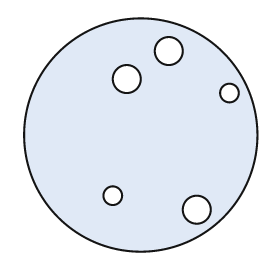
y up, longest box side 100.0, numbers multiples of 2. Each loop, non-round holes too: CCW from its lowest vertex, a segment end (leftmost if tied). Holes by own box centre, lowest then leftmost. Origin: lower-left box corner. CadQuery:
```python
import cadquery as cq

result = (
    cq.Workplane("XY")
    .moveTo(50.0, 50.0)
    .circle(50.0)
    .moveTo(74.0, 18.0)
    .circle(6.0)
    .moveTo(38.0, 24.0)
    .circle(4.0)
    .moveTo(88.0, 68.0)
    .circle(4.0)
    .moveTo(44.0, 74.0)
    .circle(6.0)
    .moveTo(62.0, 86.0)
    .circle(6.0)
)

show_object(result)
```